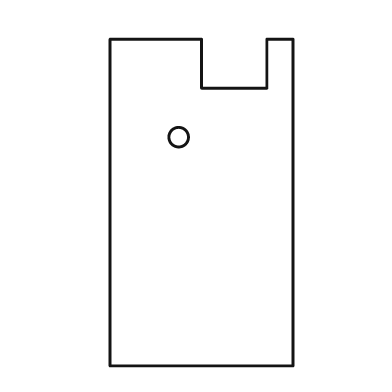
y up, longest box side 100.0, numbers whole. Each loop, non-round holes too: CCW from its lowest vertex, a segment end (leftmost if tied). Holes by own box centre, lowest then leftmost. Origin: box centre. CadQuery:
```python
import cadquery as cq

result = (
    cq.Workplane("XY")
    .moveTo(-28.0, -50.0)
    .lineTo(28.0, -50.0)
    .lineTo(28.0, 50.0)
    .lineTo(20.0, 50.0)
    .lineTo(20.0, 35.0)
    .lineTo(0.0, 35.0)
    .lineTo(0.0, 50.0)
    .lineTo(-28.0, 50.0)
    .close()
    .moveTo(-7.0, 20.0)
    .circle(3.0)
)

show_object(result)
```